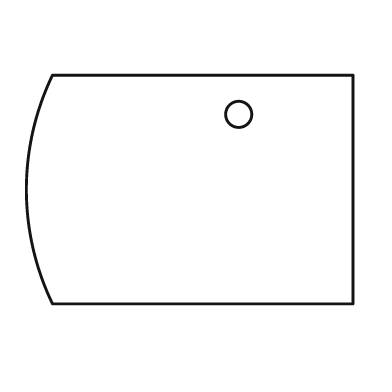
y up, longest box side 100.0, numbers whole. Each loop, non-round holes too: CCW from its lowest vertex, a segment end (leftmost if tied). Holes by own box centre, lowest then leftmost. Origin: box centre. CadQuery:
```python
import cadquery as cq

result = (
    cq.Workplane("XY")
    .moveTo(-42.0, -35.0)
    .lineTo(50.0, -35.0)
    .lineTo(50.0, 35.0)
    .lineTo(-42.0, 35.0)
    .threePointArc((-50.0, 0.0), (-42.0, -35.0))
    .close()
    .moveTo(15.0, 23.0)
    .circle(4.0)
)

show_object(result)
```